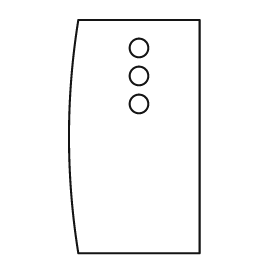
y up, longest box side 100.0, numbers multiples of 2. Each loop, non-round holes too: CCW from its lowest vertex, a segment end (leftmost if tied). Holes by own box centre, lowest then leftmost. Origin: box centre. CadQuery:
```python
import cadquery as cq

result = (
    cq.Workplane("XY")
    .moveTo(-24.0, -50.0)
    .lineTo(28.0, -50.0)
    .lineTo(28.0, 50.0)
    .lineTo(-24.0, 50.0)
    .threePointArc((-28.0, 0.0), (-24.0, -50.0))
    .close()
    .moveTo(2.0, 14.0)
    .circle(4.0)
    .moveTo(2.0, 26.0)
    .circle(4.0)
    .moveTo(2.0, 38.0)
    .circle(4.0)
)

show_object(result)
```